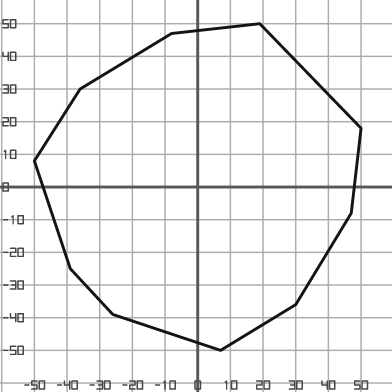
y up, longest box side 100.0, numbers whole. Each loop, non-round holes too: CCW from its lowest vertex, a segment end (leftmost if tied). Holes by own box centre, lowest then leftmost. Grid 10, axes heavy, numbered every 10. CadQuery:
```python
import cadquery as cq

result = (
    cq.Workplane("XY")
    .moveTo(7.0, -50.0)
    .lineTo(30.0, -36.0)
    .lineTo(47.0, -8.0)
    .lineTo(50.0, 18.0)
    .lineTo(19.0, 50.0)
    .lineTo(-8.0, 47.0)
    .lineTo(-36.0, 30.0)
    .lineTo(-50.0, 8.0)
    .lineTo(-39.0, -25.0)
    .lineTo(-26.0, -39.0)
    .close()
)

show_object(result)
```